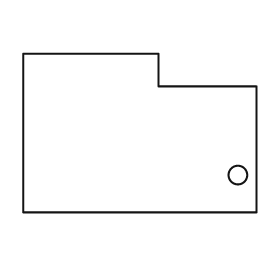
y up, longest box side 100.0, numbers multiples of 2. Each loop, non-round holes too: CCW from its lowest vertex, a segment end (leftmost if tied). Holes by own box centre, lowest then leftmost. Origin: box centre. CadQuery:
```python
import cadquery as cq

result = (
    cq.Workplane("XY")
    .moveTo(-50.0, -34.0)
    .lineTo(50.0, -34.0)
    .lineTo(50.0, 20.0)
    .lineTo(8.0, 20.0)
    .lineTo(8.0, 34.0)
    .lineTo(-50.0, 34.0)
    .close()
    .moveTo(42.0, -18.0)
    .circle(4.0)
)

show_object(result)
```